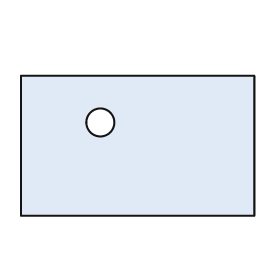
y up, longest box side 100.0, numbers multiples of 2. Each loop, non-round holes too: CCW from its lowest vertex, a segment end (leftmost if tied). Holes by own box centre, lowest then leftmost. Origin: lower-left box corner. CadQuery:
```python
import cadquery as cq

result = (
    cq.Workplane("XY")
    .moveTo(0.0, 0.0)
    .lineTo(100.0, 0.0)
    .lineTo(100.0, 60.0)
    .lineTo(0.0, 60.0)
    .close()
    .moveTo(34.0, 40.0)
    .circle(6.0)
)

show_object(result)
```